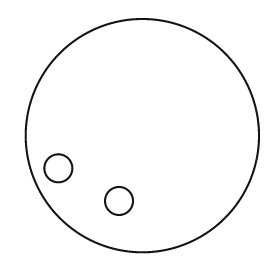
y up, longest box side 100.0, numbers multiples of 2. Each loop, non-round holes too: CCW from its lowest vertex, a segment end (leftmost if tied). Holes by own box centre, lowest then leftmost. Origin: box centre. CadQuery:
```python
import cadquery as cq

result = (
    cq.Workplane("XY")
    .moveTo(0.0, 0.0)
    .circle(50.0)
    .moveTo(-10.0, -28.0)
    .circle(6.0)
    .moveTo(-36.0, -14.0)
    .circle(6.0)
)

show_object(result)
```